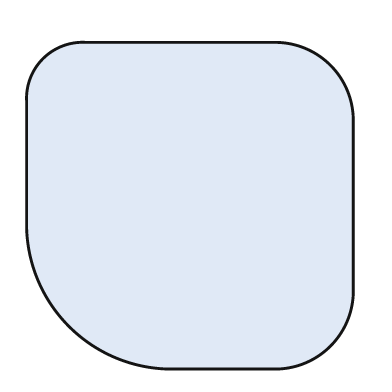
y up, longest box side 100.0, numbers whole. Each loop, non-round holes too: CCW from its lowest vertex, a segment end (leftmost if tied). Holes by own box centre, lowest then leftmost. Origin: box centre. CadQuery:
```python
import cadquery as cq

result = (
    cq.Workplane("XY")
    .moveTo(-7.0, -50.0)
    .lineTo(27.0, -50.0)
    .threePointArc((43.0, -43.0), (50.0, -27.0))
    .lineTo(50.0, 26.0)
    .threePointArc((43.0, 43.0), (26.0, 50.0))
    .lineTo(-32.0, 50.0)
    .threePointArc((-45.0, 45.0), (-50.0, 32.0))
    .lineTo(-50.0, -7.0)
    .threePointArc((-37.0, -37.0), (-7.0, -50.0))
    .close()
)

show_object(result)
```